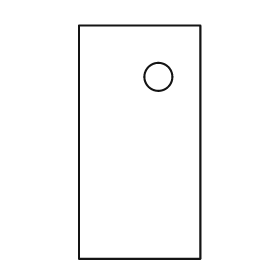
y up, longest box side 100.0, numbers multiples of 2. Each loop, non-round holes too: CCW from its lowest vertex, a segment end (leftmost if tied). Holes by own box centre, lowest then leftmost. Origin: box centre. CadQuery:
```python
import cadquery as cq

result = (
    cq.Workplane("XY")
    .moveTo(-26.0, -50.0)
    .lineTo(26.0, -50.0)
    .lineTo(26.0, 50.0)
    .lineTo(-26.0, 50.0)
    .close()
    .moveTo(8.0, 28.0)
    .circle(6.0)
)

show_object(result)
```